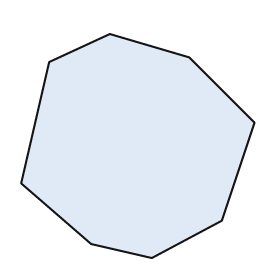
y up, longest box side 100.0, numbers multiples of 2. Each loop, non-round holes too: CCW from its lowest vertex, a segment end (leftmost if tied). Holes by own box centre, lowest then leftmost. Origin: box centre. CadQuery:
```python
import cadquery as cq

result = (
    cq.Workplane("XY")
    .moveTo(6.0, -48.0)
    .lineTo(36.0, -32.0)
    .lineTo(50.0, 10.0)
    .lineTo(22.0, 38.0)
    .lineTo(-12.0, 48.0)
    .lineTo(-38.0, 36.0)
    .lineTo(-50.0, -16.0)
    .lineTo(-20.0, -42.0)
    .close()
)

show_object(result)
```